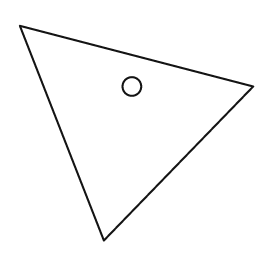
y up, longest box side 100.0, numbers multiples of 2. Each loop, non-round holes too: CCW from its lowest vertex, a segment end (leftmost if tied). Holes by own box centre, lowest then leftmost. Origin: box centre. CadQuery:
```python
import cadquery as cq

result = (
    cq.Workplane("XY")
    .moveTo(-14.0, -46.0)
    .lineTo(50.0, 20.0)
    .lineTo(-50.0, 46.0)
    .close()
    .moveTo(-2.0, 20.0)
    .circle(4.0)
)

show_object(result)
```